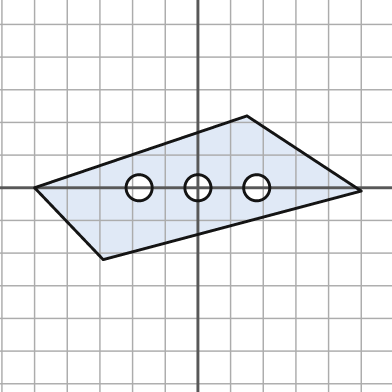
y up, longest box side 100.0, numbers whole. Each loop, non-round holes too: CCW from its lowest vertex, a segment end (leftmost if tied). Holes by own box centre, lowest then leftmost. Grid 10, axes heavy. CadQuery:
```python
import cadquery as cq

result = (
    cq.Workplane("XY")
    .moveTo(-29.0, -22.0)
    .lineTo(50.0, -1.0)
    .lineTo(15.0, 22.0)
    .lineTo(-50.0, 0.0)
    .close()
    .moveTo(-18.0, 0.0)
    .circle(4.0)
    .moveTo(0.0, 0.0)
    .circle(4.0)
    .moveTo(18.0, 0.0)
    .circle(4.0)
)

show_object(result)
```